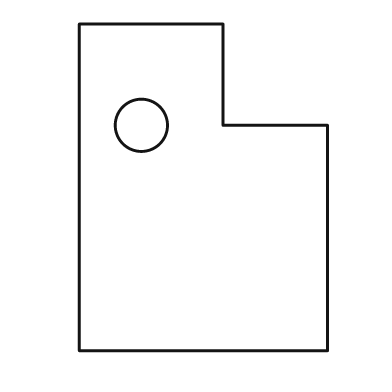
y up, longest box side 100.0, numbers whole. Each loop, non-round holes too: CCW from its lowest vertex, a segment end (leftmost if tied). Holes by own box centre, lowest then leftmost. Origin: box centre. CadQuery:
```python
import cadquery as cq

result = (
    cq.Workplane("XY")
    .moveTo(-38.0, -50.0)
    .lineTo(38.0, -50.0)
    .lineTo(38.0, 19.0)
    .lineTo(6.0, 19.0)
    .lineTo(6.0, 50.0)
    .lineTo(-38.0, 50.0)
    .close()
    .moveTo(-19.0, 19.0)
    .circle(8.0)
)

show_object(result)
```